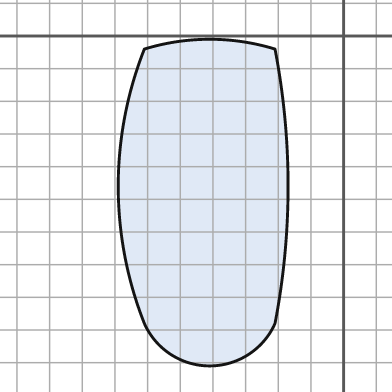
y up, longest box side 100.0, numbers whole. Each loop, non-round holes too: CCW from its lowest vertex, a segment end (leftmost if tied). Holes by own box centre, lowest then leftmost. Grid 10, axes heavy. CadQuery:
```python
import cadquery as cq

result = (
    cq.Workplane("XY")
    .moveTo(-61.0, -88.0)
    .threePointArc((-41.0, -101.0), (-21.0, -88.0))
    .threePointArc((-17.0, -46.0), (-21.0, -4.0))
    .threePointArc((-41.0, -1.0), (-61.0, -4.0))
    .threePointArc((-69.0, -46.0), (-61.0, -88.0))
    .close()
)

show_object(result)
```